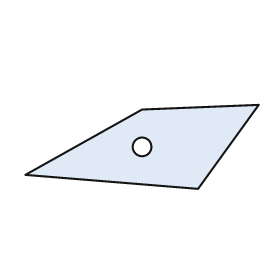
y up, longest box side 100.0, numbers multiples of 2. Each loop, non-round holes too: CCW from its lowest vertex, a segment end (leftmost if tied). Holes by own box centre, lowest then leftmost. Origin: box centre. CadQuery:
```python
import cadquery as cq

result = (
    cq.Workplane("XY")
    .moveTo(24.0, -18.0)
    .lineTo(50.0, 18.0)
    .lineTo(0.0, 16.0)
    .lineTo(-50.0, -12.0)
    .close()
    .moveTo(0.0, 0.0)
    .circle(4.0)
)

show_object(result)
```